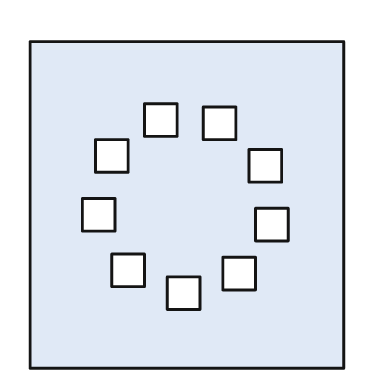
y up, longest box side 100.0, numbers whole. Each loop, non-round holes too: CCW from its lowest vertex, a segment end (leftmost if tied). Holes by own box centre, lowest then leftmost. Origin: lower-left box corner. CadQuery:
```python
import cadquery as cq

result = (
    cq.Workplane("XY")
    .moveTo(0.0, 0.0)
    .lineTo(96.0, 0.0)
    .lineTo(96.0, 100.0)
    .lineTo(0.0, 100.0)
    .close()
    .moveTo(42.0, 18.0)
    .lineTo(52.0, 18.0)
    .lineTo(52.0, 28.0)
    .lineTo(42.0, 28.0)
    .close()
    .moveTo(59.0, 24.0)
    .lineTo(69.0, 24.0)
    .lineTo(69.0, 34.0)
    .lineTo(59.0, 34.0)
    .close()
    .moveTo(25.0, 25.0)
    .lineTo(35.0, 25.0)
    .lineTo(35.0, 35.0)
    .lineTo(25.0, 35.0)
    .close()
    .moveTo(69.0, 39.0)
    .lineTo(79.0, 39.0)
    .lineTo(79.0, 49.0)
    .lineTo(69.0, 49.0)
    .close()
    .moveTo(16.0, 42.0)
    .lineTo(26.0, 42.0)
    .lineTo(26.0, 52.0)
    .lineTo(16.0, 52.0)
    .close()
    .moveTo(67.0, 57.0)
    .lineTo(77.0, 57.0)
    .lineTo(77.0, 67.0)
    .lineTo(67.0, 67.0)
    .close()
    .moveTo(20.0, 60.0)
    .lineTo(30.0, 60.0)
    .lineTo(30.0, 70.0)
    .lineTo(20.0, 70.0)
    .close()
    .moveTo(53.0, 70.0)
    .lineTo(63.0, 70.0)
    .lineTo(63.0, 80.0)
    .lineTo(53.0, 80.0)
    .close()
    .moveTo(35.0, 71.0)
    .lineTo(45.0, 71.0)
    .lineTo(45.0, 81.0)
    .lineTo(35.0, 81.0)
    .close()
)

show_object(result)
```